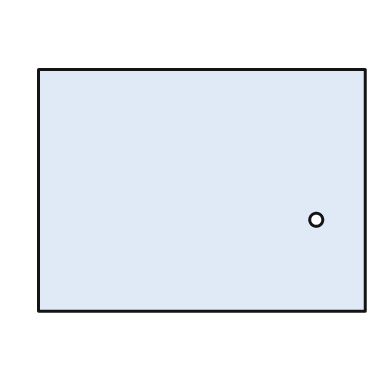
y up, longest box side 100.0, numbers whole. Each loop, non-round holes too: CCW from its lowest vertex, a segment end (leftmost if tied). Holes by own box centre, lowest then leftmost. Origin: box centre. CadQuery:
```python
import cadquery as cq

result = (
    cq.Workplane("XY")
    .moveTo(-50.0, -37.0)
    .lineTo(50.0, -37.0)
    .lineTo(50.0, 37.0)
    .lineTo(-50.0, 37.0)
    .close()
    .moveTo(35.0, -9.0)
    .circle(2.0)
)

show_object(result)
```